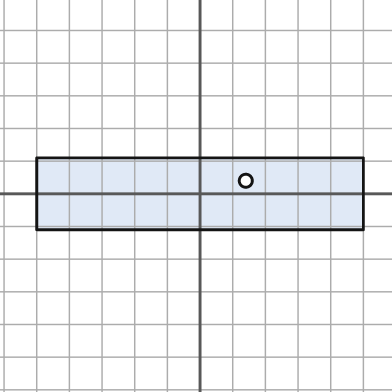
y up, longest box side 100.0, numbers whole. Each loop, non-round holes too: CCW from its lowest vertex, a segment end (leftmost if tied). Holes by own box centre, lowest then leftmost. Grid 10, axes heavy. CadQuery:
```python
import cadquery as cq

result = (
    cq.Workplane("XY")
    .moveTo(-50.0, -11.0)
    .lineTo(50.0, -11.0)
    .lineTo(50.0, 11.0)
    .lineTo(-50.0, 11.0)
    .close()
    .moveTo(14.0, 4.0)
    .circle(2.0)
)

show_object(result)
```